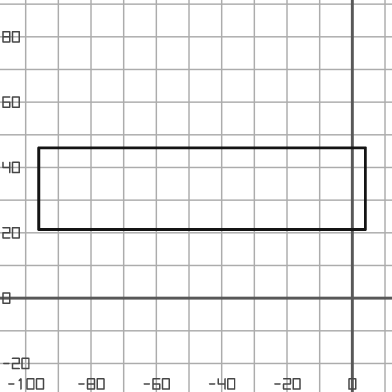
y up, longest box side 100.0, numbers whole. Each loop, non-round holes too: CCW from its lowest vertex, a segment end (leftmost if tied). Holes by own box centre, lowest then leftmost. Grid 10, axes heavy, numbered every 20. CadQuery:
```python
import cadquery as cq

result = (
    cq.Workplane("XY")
    .moveTo(-96.0, 21.0)
    .lineTo(4.0, 21.0)
    .lineTo(4.0, 46.0)
    .lineTo(-96.0, 46.0)
    .close()
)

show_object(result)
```